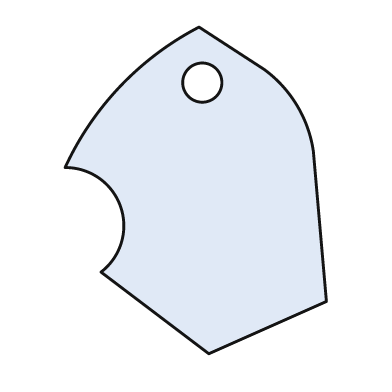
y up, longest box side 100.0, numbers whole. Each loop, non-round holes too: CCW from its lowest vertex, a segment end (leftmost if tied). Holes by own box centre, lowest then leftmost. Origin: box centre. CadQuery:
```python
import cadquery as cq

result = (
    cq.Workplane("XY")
    .moveTo(4.0, -50.0)
    .lineTo(40.0, -34.0)
    .lineTo(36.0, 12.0)
    .threePointArc((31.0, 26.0), (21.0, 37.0))
    .lineTo(1.0, 50.0)
    .threePointArc((-23.0, 32.0), (-40.0, 7.0))
    .threePointArc((-23.0, -5.0), (-29.0, -25.0))
    .close()
    .moveTo(2.0, 33.0)
    .circle(6.0)
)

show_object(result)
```